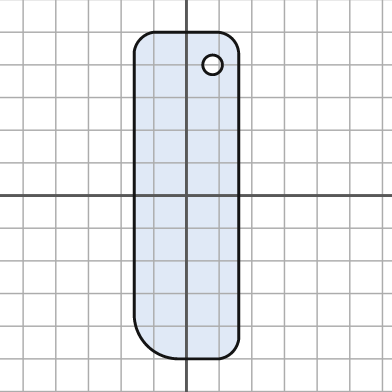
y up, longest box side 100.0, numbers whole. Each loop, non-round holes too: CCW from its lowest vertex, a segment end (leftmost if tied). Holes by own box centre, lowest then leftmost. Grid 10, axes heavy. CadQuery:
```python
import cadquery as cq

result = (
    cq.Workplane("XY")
    .moveTo(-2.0, -50.0)
    .lineTo(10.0, -50.0)
    .threePointArc((14.0, -48.0), (16.0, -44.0))
    .lineTo(16.0, 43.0)
    .threePointArc((14.0, 48.0), (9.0, 50.0))
    .lineTo(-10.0, 50.0)
    .threePointArc((-14.0, 48.0), (-16.0, 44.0))
    .lineTo(-16.0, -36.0)
    .threePointArc((-12.0, -46.0), (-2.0, -50.0))
    .close()
    .moveTo(8.0, 40.0)
    .circle(3.0)
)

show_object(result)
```